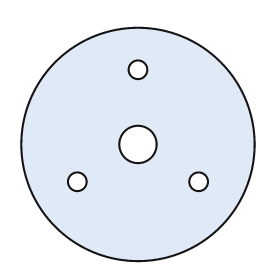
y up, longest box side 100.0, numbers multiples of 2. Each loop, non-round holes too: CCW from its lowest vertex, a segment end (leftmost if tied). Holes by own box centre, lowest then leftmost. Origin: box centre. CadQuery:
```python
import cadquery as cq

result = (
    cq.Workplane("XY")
    .moveTo(0.0, 0.0)
    .circle(50.0)
    .moveTo(-26.0, -16.0)
    .circle(4.0)
    .moveTo(26.0, -16.0)
    .circle(4.0)
    .moveTo(0.0, 0.0)
    .circle(8.0)
    .moveTo(0.0, 32.0)
    .circle(4.0)
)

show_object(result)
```